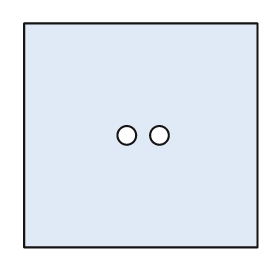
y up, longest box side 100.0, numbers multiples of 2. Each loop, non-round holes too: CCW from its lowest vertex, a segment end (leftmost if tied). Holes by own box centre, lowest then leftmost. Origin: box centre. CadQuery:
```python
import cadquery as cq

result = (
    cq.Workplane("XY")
    .moveTo(-50.0, -48.0)
    .lineTo(50.0, -48.0)
    .lineTo(50.0, 48.0)
    .lineTo(-50.0, 48.0)
    .close()
    .moveTo(-6.0, 0.0)
    .circle(4.0)
    .moveTo(8.0, 0.0)
    .circle(4.0)
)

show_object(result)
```